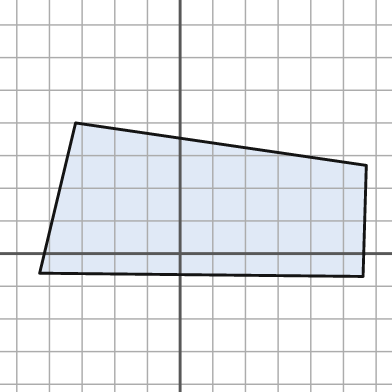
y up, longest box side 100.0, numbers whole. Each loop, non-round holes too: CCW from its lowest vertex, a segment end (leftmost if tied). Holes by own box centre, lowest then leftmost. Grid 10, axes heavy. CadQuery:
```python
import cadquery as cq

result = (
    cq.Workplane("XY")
    .moveTo(56.0, -7.0)
    .lineTo(57.0, 27.0)
    .lineTo(-32.0, 40.0)
    .lineTo(-43.0, -6.0)
    .close()
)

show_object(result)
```